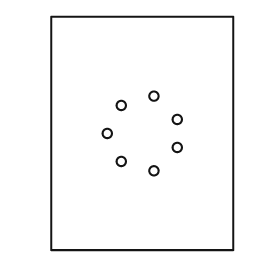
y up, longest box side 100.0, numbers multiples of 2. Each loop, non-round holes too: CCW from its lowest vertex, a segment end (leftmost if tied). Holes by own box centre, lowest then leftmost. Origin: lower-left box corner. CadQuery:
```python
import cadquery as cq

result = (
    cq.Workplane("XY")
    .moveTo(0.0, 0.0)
    .lineTo(78.0, 0.0)
    .lineTo(78.0, 100.0)
    .lineTo(0.0, 100.0)
    .close()
    .moveTo(44.0, 34.0)
    .circle(2.0)
    .moveTo(30.0, 38.0)
    .circle(2.0)
    .moveTo(54.0, 44.0)
    .circle(2.0)
    .moveTo(24.0, 50.0)
    .circle(2.0)
    .moveTo(54.0, 56.0)
    .circle(2.0)
    .moveTo(30.0, 62.0)
    .circle(2.0)
    .moveTo(44.0, 66.0)
    .circle(2.0)
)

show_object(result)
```